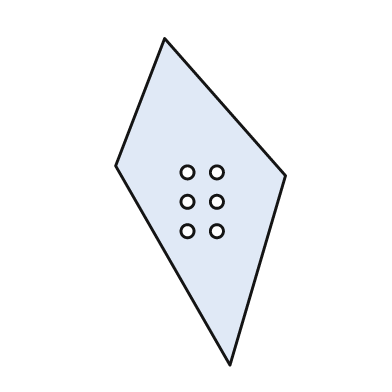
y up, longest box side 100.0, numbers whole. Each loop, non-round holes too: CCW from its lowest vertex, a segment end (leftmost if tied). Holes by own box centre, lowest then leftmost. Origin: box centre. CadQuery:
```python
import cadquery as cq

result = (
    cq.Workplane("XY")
    .moveTo(9.0, -50.0)
    .lineTo(26.0, 8.0)
    .lineTo(-11.0, 50.0)
    .lineTo(-26.0, 11.0)
    .close()
    .moveTo(-4.0, -9.0)
    .circle(2.0)
    .moveTo(5.0, -9.0)
    .circle(2.0)
    .moveTo(-4.0, 0.0)
    .circle(2.0)
    .moveTo(5.0, 0.0)
    .circle(2.0)
    .moveTo(-4.0, 9.0)
    .circle(2.0)
    .moveTo(5.0, 9.0)
    .circle(2.0)
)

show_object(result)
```